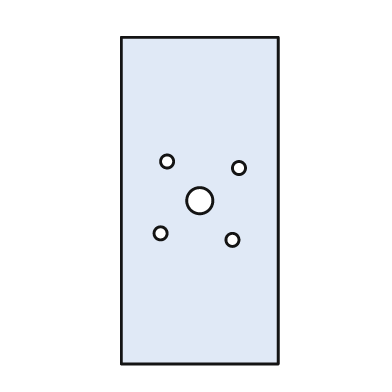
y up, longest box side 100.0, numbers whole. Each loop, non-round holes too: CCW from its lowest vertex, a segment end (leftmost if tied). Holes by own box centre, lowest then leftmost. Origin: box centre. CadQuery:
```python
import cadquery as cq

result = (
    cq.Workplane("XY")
    .moveTo(-24.0, -50.0)
    .lineTo(24.0, -50.0)
    .lineTo(24.0, 50.0)
    .lineTo(-24.0, 50.0)
    .close()
    .moveTo(10.0, -12.0)
    .circle(2.0)
    .moveTo(-12.0, -10.0)
    .circle(2.0)
    .moveTo(0.0, 0.0)
    .circle(4.0)
    .moveTo(12.0, 10.0)
    .circle(2.0)
    .moveTo(-10.0, 12.0)
    .circle(2.0)
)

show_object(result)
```